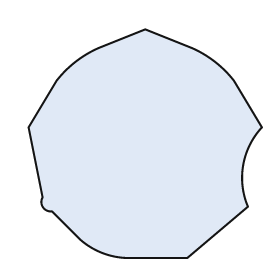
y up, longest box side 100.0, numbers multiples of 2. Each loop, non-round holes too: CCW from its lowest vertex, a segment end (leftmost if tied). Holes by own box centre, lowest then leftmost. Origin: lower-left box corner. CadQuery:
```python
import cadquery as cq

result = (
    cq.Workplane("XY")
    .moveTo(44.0, 0.0)
    .lineTo(68.0, 0.0)
    .lineTo(94.0, 22.0)
    .threePointArc((92.0, 40.0), (100.0, 56.0))
    .lineTo(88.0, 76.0)
    .threePointArc((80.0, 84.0), (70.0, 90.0))
    .lineTo(50.0, 98.0)
    .lineTo(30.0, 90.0)
    .threePointArc((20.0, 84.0), (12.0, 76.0))
    .lineTo(0.0, 56.0)
    .lineTo(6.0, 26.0)
    .threePointArc((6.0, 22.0), (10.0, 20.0))
    .lineTo(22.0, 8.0)
    .threePointArc((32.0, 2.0), (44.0, 0.0))
    .close()
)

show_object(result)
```